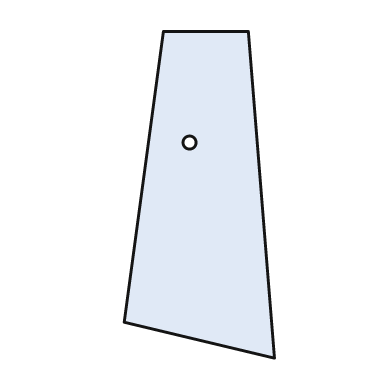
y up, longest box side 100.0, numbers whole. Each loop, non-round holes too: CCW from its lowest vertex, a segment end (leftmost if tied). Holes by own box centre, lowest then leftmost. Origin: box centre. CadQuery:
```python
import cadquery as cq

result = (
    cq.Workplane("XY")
    .moveTo(23.0, -50.0)
    .lineTo(15.0, 50.0)
    .lineTo(-11.0, 50.0)
    .lineTo(-23.0, -39.0)
    .close()
    .moveTo(-3.0, 16.0)
    .circle(2.0)
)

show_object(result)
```